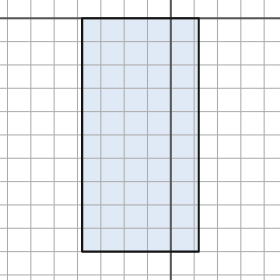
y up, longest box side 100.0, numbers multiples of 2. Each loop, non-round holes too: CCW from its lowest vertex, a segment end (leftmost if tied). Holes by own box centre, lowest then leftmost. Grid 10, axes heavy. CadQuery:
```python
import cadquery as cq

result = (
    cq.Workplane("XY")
    .moveTo(-38.0, -100.0)
    .lineTo(12.0, -100.0)
    .lineTo(12.0, 0.0)
    .lineTo(-38.0, 0.0)
    .close()
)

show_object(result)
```